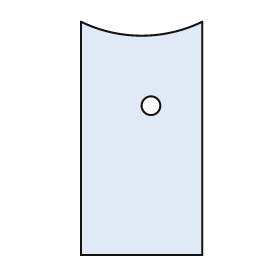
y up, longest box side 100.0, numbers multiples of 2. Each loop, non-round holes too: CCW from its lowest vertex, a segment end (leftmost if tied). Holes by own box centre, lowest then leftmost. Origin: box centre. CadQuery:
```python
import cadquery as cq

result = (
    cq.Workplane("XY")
    .moveTo(-26.0, -50.0)
    .lineTo(26.0, -50.0)
    .lineTo(26.0, 50.0)
    .threePointArc((0.0, 44.0), (-26.0, 50.0))
    .close()
    .moveTo(4.0, 14.0)
    .circle(4.0)
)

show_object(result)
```